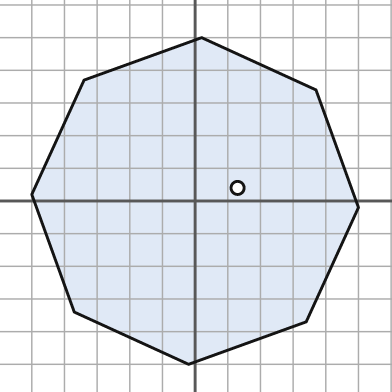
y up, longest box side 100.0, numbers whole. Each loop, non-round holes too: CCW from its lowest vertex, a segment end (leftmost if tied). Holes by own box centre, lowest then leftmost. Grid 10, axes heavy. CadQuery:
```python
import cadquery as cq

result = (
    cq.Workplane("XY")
    .moveTo(-2.0, -50.0)
    .lineTo(34.0, -37.0)
    .lineTo(50.0, -2.0)
    .lineTo(37.0, 34.0)
    .lineTo(2.0, 50.0)
    .lineTo(-34.0, 37.0)
    .lineTo(-50.0, 2.0)
    .lineTo(-37.0, -34.0)
    .close()
    .moveTo(13.0, 4.0)
    .circle(2.0)
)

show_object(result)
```